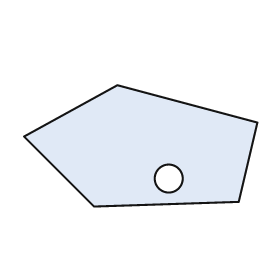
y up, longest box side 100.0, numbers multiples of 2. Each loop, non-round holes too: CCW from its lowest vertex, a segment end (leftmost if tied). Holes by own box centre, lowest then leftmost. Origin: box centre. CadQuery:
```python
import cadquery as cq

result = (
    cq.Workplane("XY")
    .moveTo(-20.0, -26.0)
    .lineTo(42.0, -24.0)
    .lineTo(50.0, 10.0)
    .lineTo(-10.0, 26.0)
    .lineTo(-50.0, 4.0)
    .close()
    .moveTo(12.0, -14.0)
    .circle(6.0)
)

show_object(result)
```